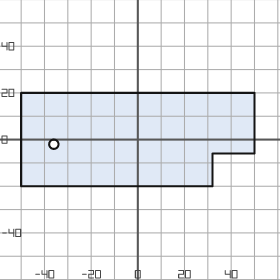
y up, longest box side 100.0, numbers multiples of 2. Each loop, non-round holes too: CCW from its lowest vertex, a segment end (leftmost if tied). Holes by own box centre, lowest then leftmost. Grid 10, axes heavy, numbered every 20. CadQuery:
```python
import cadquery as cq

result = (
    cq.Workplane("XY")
    .moveTo(-50.0, -20.0)
    .lineTo(32.0, -20.0)
    .lineTo(32.0, -6.0)
    .lineTo(50.0, -6.0)
    .lineTo(50.0, 20.0)
    .lineTo(-50.0, 20.0)
    .close()
    .moveTo(-36.0, -2.0)
    .circle(2.0)
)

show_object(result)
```